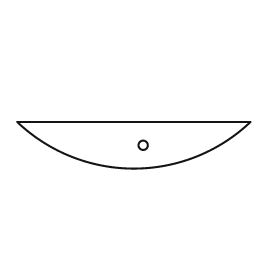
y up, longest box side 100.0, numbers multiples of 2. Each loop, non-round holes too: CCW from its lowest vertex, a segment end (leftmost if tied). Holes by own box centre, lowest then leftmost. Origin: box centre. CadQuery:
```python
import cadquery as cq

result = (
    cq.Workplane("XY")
    .moveTo(-50.0, 10.0)
    .threePointArc((0.0, -10.0), (50.0, 10.0))
    .close()
    .moveTo(4.0, 0.0)
    .circle(2.0)
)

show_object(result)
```